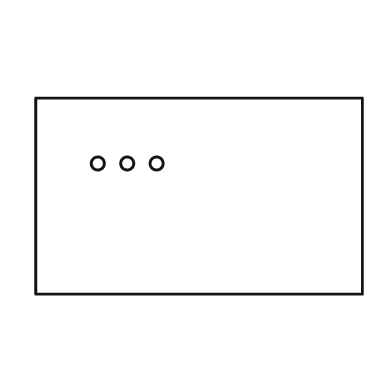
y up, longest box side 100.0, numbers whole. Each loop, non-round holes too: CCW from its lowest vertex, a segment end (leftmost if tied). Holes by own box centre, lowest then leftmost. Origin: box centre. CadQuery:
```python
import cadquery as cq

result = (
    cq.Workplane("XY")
    .moveTo(-50.0, -30.0)
    .lineTo(50.0, -30.0)
    .lineTo(50.0, 30.0)
    .lineTo(-50.0, 30.0)
    .close()
    .moveTo(-31.0, 10.0)
    .circle(2.0)
    .moveTo(-22.0, 10.0)
    .circle(2.0)
    .moveTo(-13.0, 10.0)
    .circle(2.0)
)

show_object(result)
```